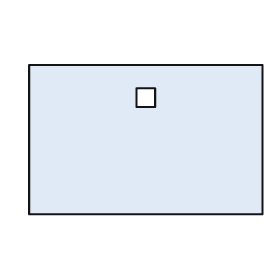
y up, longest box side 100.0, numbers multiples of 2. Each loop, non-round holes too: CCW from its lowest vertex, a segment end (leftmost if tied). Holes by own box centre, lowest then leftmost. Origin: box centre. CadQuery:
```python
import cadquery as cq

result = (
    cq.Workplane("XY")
    .moveTo(-50.0, -32.0)
    .lineTo(50.0, -32.0)
    .lineTo(50.0, 32.0)
    .lineTo(-50.0, 32.0)
    .close()
    .moveTo(-4.0, 14.0)
    .lineTo(4.0, 14.0)
    .lineTo(4.0, 22.0)
    .lineTo(-4.0, 22.0)
    .close()
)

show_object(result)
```